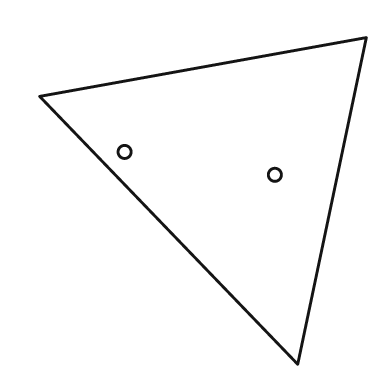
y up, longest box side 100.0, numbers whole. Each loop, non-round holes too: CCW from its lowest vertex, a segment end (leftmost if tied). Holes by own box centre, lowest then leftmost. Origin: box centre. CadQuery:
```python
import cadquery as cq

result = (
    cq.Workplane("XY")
    .moveTo(29.0, -50.0)
    .lineTo(50.0, 50.0)
    .lineTo(-50.0, 32.0)
    .close()
    .moveTo(22.0, 8.0)
    .circle(2.0)
    .moveTo(-24.0, 15.0)
    .circle(2.0)
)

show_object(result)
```